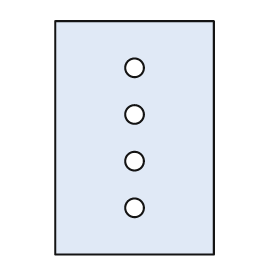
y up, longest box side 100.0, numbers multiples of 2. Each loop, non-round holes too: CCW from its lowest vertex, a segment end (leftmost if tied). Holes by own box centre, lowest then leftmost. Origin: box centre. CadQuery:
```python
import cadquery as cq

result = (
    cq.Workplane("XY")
    .moveTo(-34.0, -50.0)
    .lineTo(34.0, -50.0)
    .lineTo(34.0, 50.0)
    .lineTo(-34.0, 50.0)
    .close()
    .moveTo(0.0, -30.0)
    .circle(4.0)
    .moveTo(0.0, -10.0)
    .circle(4.0)
    .moveTo(0.0, 10.0)
    .circle(4.0)
    .moveTo(0.0, 30.0)
    .circle(4.0)
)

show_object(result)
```